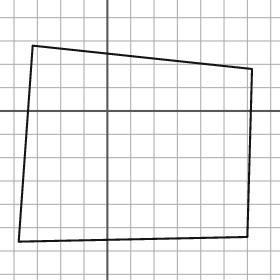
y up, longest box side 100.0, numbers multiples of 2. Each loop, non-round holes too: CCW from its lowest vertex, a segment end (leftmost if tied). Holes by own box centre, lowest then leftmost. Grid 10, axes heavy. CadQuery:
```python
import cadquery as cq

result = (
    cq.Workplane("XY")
    .moveTo(-38.0, -56.0)
    .lineTo(60.0, -54.0)
    .lineTo(62.0, 18.0)
    .lineTo(-32.0, 28.0)
    .close()
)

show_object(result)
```